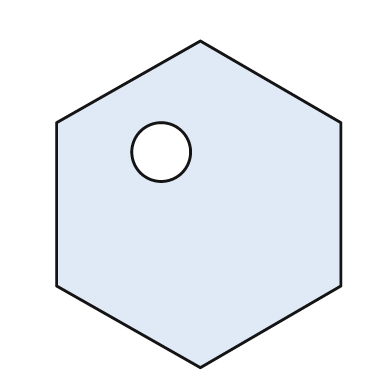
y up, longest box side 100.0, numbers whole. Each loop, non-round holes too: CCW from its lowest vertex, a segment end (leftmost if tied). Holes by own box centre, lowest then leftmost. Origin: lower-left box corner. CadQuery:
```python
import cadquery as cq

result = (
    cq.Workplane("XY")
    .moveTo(44.0, 0.0)
    .lineTo(87.0, 25.0)
    .lineTo(87.0, 75.0)
    .lineTo(44.0, 100.0)
    .lineTo(0.0, 75.0)
    .lineTo(0.0, 25.0)
    .close()
    .moveTo(32.0, 66.0)
    .circle(9.0)
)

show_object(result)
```